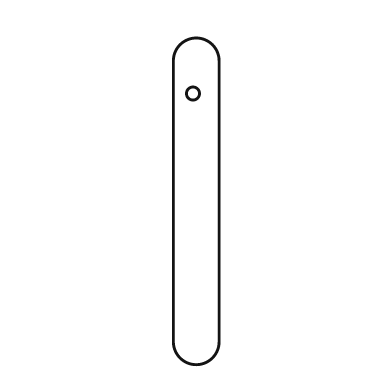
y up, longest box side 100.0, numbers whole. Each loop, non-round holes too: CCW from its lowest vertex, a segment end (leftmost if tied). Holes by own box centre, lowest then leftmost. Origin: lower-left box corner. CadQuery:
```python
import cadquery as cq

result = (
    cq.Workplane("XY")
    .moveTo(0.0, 7.0)
    .threePointArc((7.0, 0.0), (14.0, 7.0))
    .lineTo(14.0, 93.0)
    .threePointArc((7.0, 100.0), (0.0, 93.0))
    .close()
    .moveTo(6.0, 83.0)
    .circle(2.0)
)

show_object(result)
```